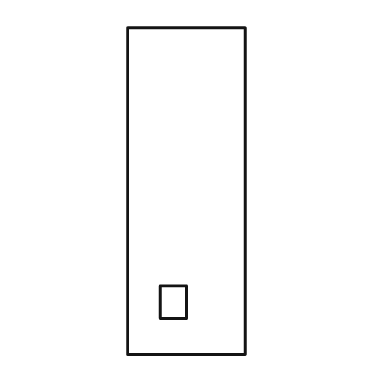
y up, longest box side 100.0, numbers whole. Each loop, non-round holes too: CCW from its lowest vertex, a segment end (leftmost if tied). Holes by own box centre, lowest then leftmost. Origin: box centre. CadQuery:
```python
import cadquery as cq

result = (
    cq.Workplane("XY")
    .moveTo(-18.0, -50.0)
    .lineTo(18.0, -50.0)
    .lineTo(18.0, 50.0)
    .lineTo(-18.0, 50.0)
    .close()
    .moveTo(-8.0, -39.0)
    .lineTo(0.0, -39.0)
    .lineTo(0.0, -29.0)
    .lineTo(-8.0, -29.0)
    .close()
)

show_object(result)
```